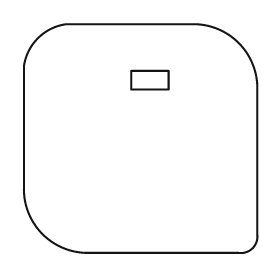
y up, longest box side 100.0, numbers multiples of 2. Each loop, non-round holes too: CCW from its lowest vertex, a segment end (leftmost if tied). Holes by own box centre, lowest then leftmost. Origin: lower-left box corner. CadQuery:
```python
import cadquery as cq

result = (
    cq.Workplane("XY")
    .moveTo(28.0, 0.0)
    .lineTo(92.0, 0.0)
    .threePointArc((98.0, 2.0), (100.0, 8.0))
    .lineTo(100.0, 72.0)
    .threePointArc((92.0, 90.0), (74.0, 98.0))
    .lineTo(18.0, 98.0)
    .threePointArc((6.0, 92.0), (0.0, 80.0))
    .lineTo(0.0, 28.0)
    .threePointArc((8.0, 8.0), (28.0, 0.0))
    .close()
    .moveTo(46.0, 70.0)
    .lineTo(62.0, 70.0)
    .lineTo(62.0, 78.0)
    .lineTo(46.0, 78.0)
    .close()
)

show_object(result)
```